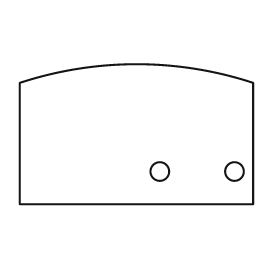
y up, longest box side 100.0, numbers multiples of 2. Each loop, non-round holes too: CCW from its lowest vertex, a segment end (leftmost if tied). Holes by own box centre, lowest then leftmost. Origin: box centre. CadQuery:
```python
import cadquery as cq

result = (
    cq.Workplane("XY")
    .moveTo(-50.0, -30.0)
    .lineTo(50.0, -30.0)
    .lineTo(50.0, 22.0)
    .threePointArc((0.0, 30.0), (-50.0, 22.0))
    .close()
    .moveTo(10.0, -16.0)
    .circle(4.0)
    .moveTo(42.0, -16.0)
    .circle(4.0)
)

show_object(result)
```